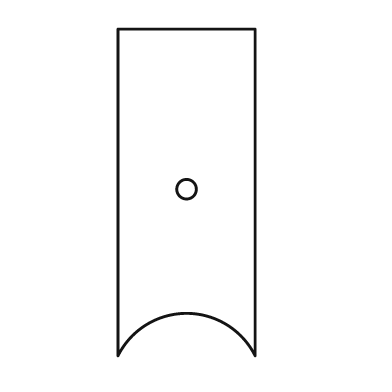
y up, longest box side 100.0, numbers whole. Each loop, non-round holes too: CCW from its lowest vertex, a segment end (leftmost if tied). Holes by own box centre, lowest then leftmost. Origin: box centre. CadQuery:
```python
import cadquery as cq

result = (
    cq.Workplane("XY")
    .moveTo(-21.0, -50.0)
    .threePointArc((0.0, -37.0), (21.0, -50.0))
    .lineTo(21.0, 50.0)
    .lineTo(-21.0, 50.0)
    .close()
    .moveTo(0.0, 1.0)
    .circle(3.0)
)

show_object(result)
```